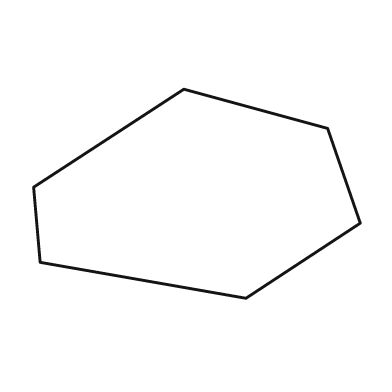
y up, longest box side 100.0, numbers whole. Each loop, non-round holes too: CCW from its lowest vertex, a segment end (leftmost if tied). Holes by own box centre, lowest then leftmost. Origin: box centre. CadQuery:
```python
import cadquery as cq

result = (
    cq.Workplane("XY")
    .moveTo(15.0, -32.0)
    .lineTo(50.0, -9.0)
    .lineTo(40.0, 20.0)
    .lineTo(-4.0, 32.0)
    .lineTo(-50.0, 2.0)
    .lineTo(-48.0, -21.0)
    .close()
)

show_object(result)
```